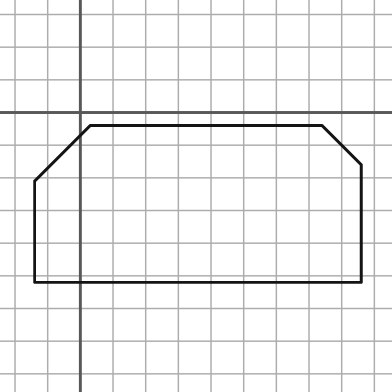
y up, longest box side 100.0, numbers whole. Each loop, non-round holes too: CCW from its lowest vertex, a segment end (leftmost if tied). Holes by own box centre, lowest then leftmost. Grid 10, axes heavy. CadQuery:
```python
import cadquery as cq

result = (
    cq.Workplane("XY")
    .moveTo(-14.0, -52.0)
    .lineTo(86.0, -52.0)
    .lineTo(86.0, -16.0)
    .lineTo(74.0, -4.0)
    .lineTo(3.0, -4.0)
    .lineTo(-14.0, -21.0)
    .close()
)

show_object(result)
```